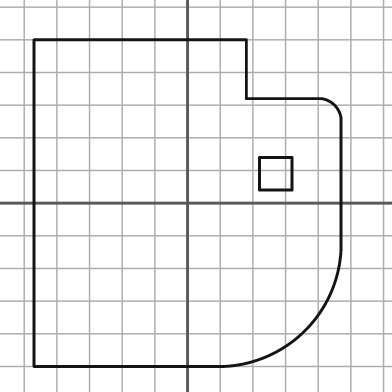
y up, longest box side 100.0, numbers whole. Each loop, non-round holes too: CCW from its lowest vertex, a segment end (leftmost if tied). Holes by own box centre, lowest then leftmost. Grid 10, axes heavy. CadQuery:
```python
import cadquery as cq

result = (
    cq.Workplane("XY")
    .moveTo(-47.0, -50.0)
    .lineTo(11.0, -50.0)
    .threePointArc((36.0, -39.0), (47.0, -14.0))
    .lineTo(47.0, 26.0)
    .threePointArc((45.0, 30.0), (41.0, 32.0))
    .lineTo(18.0, 32.0)
    .lineTo(18.0, 50.0)
    .lineTo(-47.0, 50.0)
    .close()
    .moveTo(22.0, 4.0)
    .lineTo(32.0, 4.0)
    .lineTo(32.0, 14.0)
    .lineTo(22.0, 14.0)
    .close()
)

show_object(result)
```